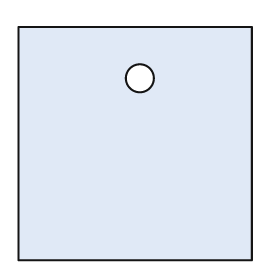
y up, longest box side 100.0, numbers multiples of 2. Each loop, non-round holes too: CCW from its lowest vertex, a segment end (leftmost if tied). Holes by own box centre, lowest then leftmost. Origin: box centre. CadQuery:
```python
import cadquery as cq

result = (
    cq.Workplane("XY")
    .moveTo(-50.0, -50.0)
    .lineTo(50.0, -50.0)
    .lineTo(50.0, 50.0)
    .lineTo(-50.0, 50.0)
    .close()
    .moveTo(2.0, 28.0)
    .circle(6.0)
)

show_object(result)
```